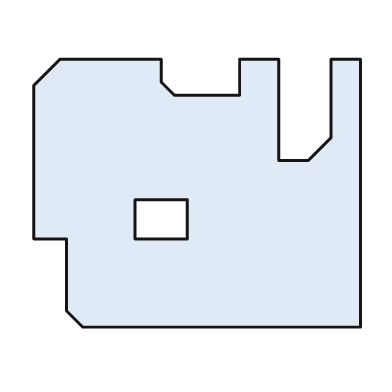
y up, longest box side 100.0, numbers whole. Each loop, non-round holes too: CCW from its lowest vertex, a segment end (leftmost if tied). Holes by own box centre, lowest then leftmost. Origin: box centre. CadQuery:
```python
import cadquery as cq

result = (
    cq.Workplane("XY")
    .moveTo(-35.0, -41.0)
    .lineTo(50.0, -41.0)
    .lineTo(50.0, 41.0)
    .lineTo(41.0, 41.0)
    .lineTo(41.0, 17.0)
    .lineTo(34.0, 10.0)
    .lineTo(25.0, 10.0)
    .lineTo(25.0, 41.0)
    .lineTo(13.0, 41.0)
    .lineTo(13.0, 30.0)
    .lineTo(-7.0, 30.0)
    .lineTo(-11.0, 34.0)
    .lineTo(-11.0, 41.0)
    .lineTo(-42.0, 41.0)
    .lineTo(-50.0, 33.0)
    .lineTo(-50.0, -14.0)
    .lineTo(-40.0, -14.0)
    .lineTo(-40.0, -36.0)
    .close()
    .moveTo(-19.0, -14.0)
    .lineTo(-3.0, -14.0)
    .lineTo(-3.0, -2.0)
    .lineTo(-19.0, -2.0)
    .close()
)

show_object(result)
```